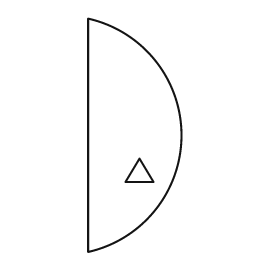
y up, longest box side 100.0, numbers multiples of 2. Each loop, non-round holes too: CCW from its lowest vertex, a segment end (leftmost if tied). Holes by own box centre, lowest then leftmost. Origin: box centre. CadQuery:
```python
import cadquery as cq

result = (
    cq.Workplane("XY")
    .moveTo(-20.0, -50.0)
    .threePointArc((20.0, 0.0), (-20.0, 50.0))
    .close()
    .moveTo(-4.0, -20.0)
    .lineTo(8.0, -20.0)
    .lineTo(2.0, -10.0)
    .close()
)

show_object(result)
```